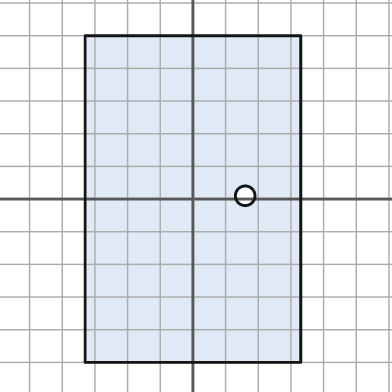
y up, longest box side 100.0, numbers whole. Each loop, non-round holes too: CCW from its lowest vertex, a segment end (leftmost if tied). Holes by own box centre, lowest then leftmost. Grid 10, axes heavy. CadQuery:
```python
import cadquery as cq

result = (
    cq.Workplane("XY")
    .moveTo(-33.0, -50.0)
    .lineTo(33.0, -50.0)
    .lineTo(33.0, 50.0)
    .lineTo(-33.0, 50.0)
    .close()
    .moveTo(16.0, 1.0)
    .circle(3.0)
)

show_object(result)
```